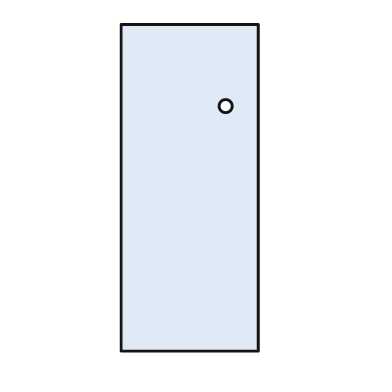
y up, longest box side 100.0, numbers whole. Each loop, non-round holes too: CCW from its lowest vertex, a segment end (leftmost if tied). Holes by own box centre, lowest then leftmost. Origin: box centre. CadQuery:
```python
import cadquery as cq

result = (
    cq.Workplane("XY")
    .moveTo(-21.0, -50.0)
    .lineTo(21.0, -50.0)
    .lineTo(21.0, 50.0)
    .lineTo(-21.0, 50.0)
    .close()
    .moveTo(11.0, 25.0)
    .circle(2.0)
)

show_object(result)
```